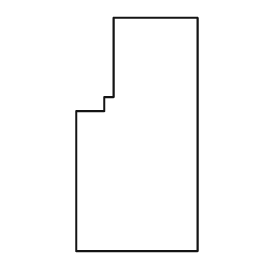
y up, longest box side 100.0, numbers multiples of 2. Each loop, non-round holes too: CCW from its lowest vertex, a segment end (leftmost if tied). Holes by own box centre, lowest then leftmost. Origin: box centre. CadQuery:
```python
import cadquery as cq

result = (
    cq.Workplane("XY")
    .moveTo(-26.0, -50.0)
    .lineTo(26.0, -50.0)
    .lineTo(26.0, 50.0)
    .lineTo(-10.0, 50.0)
    .lineTo(-10.0, 16.0)
    .lineTo(-14.0, 16.0)
    .lineTo(-14.0, 10.0)
    .lineTo(-26.0, 10.0)
    .close()
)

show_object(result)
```